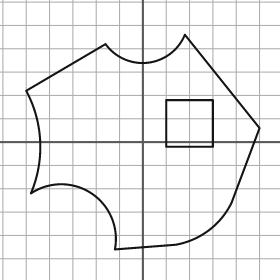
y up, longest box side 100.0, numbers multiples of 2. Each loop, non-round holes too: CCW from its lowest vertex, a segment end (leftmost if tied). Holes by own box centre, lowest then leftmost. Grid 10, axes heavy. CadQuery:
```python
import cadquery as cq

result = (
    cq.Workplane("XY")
    .moveTo(-12.0, -46.0)
    .lineTo(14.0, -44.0)
    .threePointArc((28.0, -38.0), (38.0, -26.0))
    .lineTo(50.0, 6.0)
    .lineTo(18.0, 46.0)
    .threePointArc((2.0, 34.0), (-16.0, 42.0))
    .lineTo(-50.0, 22.0)
    .threePointArc((-44.0, 0.0), (-48.0, -22.0))
    .threePointArc((-22.0, -22.0), (-12.0, -46.0))
    .close()
    .moveTo(10.0, -2.0)
    .lineTo(30.0, -2.0)
    .lineTo(30.0, 18.0)
    .lineTo(10.0, 18.0)
    .close()
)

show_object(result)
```